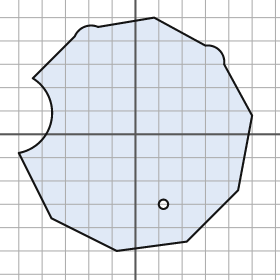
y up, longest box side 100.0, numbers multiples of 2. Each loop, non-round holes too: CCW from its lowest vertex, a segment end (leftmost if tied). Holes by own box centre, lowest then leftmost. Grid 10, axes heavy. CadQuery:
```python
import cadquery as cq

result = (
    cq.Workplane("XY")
    .moveTo(-8.0, -50.0)
    .lineTo(22.0, -46.0)
    .lineTo(44.0, -24.0)
    .lineTo(50.0, 8.0)
    .lineTo(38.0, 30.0)
    .threePointArc((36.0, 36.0), (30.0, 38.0))
    .lineTo(8.0, 50.0)
    .lineTo(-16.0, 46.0)
    .threePointArc((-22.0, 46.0), (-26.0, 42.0))
    .lineTo(-44.0, 24.0)
    .threePointArc((-36.0, 6.0), (-50.0, -8.0))
    .lineTo(-36.0, -36.0)
    .close()
    .moveTo(12.0, -30.0)
    .circle(2.0)
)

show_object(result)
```